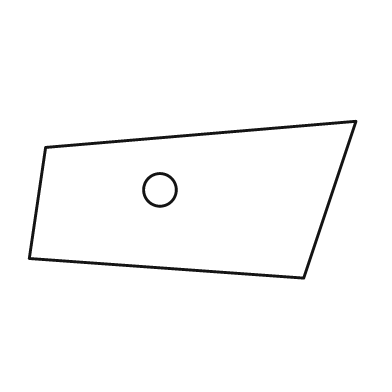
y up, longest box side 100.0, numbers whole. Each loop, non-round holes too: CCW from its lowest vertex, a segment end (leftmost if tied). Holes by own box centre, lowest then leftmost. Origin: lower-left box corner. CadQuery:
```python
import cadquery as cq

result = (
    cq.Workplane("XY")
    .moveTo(84.0, 0.0)
    .lineTo(100.0, 48.0)
    .lineTo(5.0, 40.0)
    .lineTo(0.0, 6.0)
    .close()
    .moveTo(40.0, 27.0)
    .circle(5.0)
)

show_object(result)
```